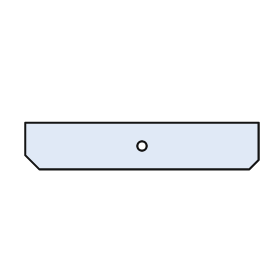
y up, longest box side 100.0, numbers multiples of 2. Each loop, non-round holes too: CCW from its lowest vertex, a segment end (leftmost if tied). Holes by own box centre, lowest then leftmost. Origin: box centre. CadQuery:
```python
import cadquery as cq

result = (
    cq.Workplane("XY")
    .moveTo(-44.0, -10.0)
    .lineTo(46.0, -10.0)
    .lineTo(50.0, -6.0)
    .lineTo(50.0, 10.0)
    .lineTo(-50.0, 10.0)
    .lineTo(-50.0, -4.0)
    .close()
    .moveTo(0.0, 0.0)
    .circle(2.0)
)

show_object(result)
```